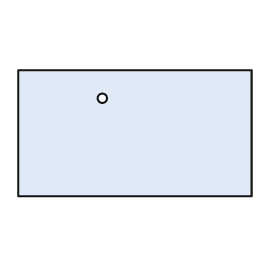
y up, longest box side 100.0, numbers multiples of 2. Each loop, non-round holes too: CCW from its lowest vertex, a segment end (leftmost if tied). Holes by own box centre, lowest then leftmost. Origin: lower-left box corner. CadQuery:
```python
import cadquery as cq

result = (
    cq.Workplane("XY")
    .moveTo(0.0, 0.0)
    .lineTo(100.0, 0.0)
    .lineTo(100.0, 54.0)
    .lineTo(0.0, 54.0)
    .close()
    .moveTo(36.0, 42.0)
    .circle(2.0)
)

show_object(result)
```